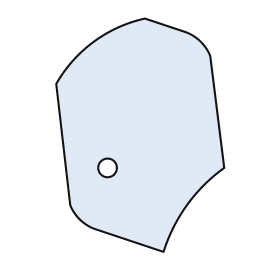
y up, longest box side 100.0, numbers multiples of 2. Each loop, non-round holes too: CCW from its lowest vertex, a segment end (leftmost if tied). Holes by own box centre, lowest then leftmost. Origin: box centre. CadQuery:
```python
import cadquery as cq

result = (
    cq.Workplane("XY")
    .moveTo(10.0, -50.0)
    .threePointArc((20.0, -30.0), (36.0, -14.0))
    .lineTo(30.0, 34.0)
    .threePointArc((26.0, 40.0), (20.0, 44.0))
    .lineTo(2.0, 50.0)
    .threePointArc((-20.0, 40.0), (-36.0, 22.0))
    .lineTo(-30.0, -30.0)
    .threePointArc((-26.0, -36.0), (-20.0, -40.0))
    .close()
    .moveTo(-14.0, -14.0)
    .circle(4.0)
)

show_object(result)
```